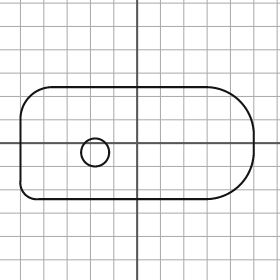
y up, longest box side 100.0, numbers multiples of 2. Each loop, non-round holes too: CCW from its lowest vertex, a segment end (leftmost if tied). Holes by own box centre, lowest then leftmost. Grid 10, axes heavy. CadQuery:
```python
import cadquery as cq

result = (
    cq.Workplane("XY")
    .moveTo(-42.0, -24.0)
    .lineTo(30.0, -24.0)
    .threePointArc((44.0, -18.0), (50.0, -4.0))
    .lineTo(50.0, 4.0)
    .threePointArc((44.0, 18.0), (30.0, 24.0))
    .lineTo(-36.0, 24.0)
    .threePointArc((-46.0, 20.0), (-50.0, 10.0))
    .lineTo(-50.0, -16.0)
    .threePointArc((-48.0, -22.0), (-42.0, -24.0))
    .close()
    .moveTo(-18.0, -4.0)
    .circle(6.0)
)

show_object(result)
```